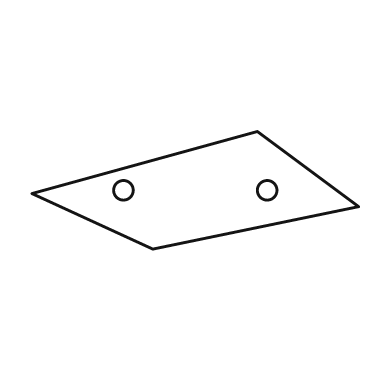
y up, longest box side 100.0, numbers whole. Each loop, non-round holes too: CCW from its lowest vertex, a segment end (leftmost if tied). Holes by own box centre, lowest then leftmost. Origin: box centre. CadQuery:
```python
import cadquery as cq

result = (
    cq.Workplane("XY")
    .moveTo(-13.0, -18.0)
    .lineTo(50.0, -5.0)
    .lineTo(19.0, 18.0)
    .lineTo(-50.0, -1.0)
    .close()
    .moveTo(-22.0, 0.0)
    .circle(3.0)
    .moveTo(22.0, 0.0)
    .circle(3.0)
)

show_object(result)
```